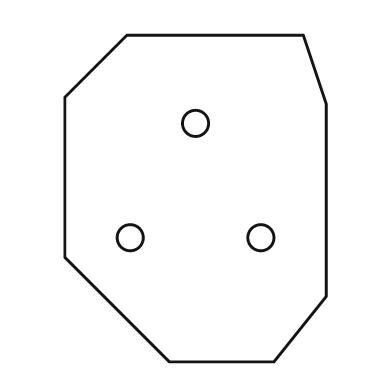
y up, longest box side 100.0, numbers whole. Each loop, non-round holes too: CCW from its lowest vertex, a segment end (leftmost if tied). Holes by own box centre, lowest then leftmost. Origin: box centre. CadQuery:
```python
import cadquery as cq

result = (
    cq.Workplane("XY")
    .moveTo(-8.0, -50.0)
    .lineTo(24.0, -50.0)
    .lineTo(40.0, -30.0)
    .lineTo(40.0, 29.0)
    .lineTo(33.0, 50.0)
    .lineTo(-21.0, 50.0)
    .lineTo(-40.0, 31.0)
    .lineTo(-40.0, -18.0)
    .close()
    .moveTo(-20.0, -12.0)
    .circle(4.0)
    .moveTo(20.0, -12.0)
    .circle(4.0)
    .moveTo(0.0, 23.0)
    .circle(4.0)
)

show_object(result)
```